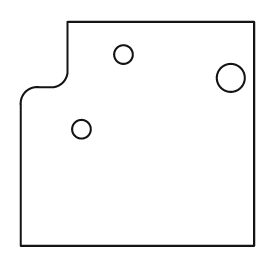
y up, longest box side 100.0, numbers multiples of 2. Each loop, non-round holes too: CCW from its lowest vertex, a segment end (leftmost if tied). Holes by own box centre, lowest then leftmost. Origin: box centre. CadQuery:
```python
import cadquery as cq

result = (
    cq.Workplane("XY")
    .moveTo(-50.0, -48.0)
    .lineTo(50.0, -48.0)
    .lineTo(50.0, 48.0)
    .lineTo(-30.0, 48.0)
    .lineTo(-30.0, 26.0)
    .threePointArc((-32.0, 22.0), (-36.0, 20.0))
    .lineTo(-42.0, 20.0)
    .threePointArc((-48.0, 18.0), (-50.0, 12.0))
    .close()
    .moveTo(-24.0, 2.0)
    .circle(4.0)
    .moveTo(40.0, 24.0)
    .circle(6.0)
    .moveTo(-6.0, 34.0)
    .circle(4.0)
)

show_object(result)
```